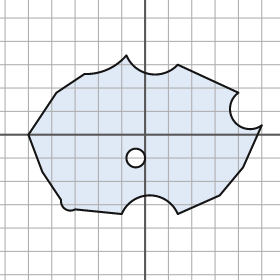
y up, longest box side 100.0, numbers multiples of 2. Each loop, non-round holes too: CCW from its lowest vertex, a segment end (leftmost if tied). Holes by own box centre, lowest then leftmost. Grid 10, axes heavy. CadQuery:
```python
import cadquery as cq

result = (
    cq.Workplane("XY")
    .moveTo(-10.0, -34.0)
    .threePointArc((2.0, -26.0), (14.0, -34.0))
    .lineTo(32.0, -26.0)
    .lineTo(42.0, -14.0)
    .lineTo(50.0, 4.0)
    .threePointArc((38.0, 6.0), (40.0, 18.0))
    .lineTo(14.0, 30.0)
    .threePointArc((2.0, 26.0), (-8.0, 34.0))
    .threePointArc((-16.0, 28.0), (-26.0, 26.0))
    .lineTo(-38.0, 18.0)
    .lineTo(-50.0, 0.0)
    .lineTo(-44.0, -16.0)
    .lineTo(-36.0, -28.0)
    .threePointArc((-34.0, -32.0), (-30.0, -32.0))
    .close()
    .moveTo(-4.0, -10.0)
    .circle(4.0)
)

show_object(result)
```